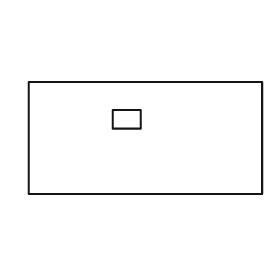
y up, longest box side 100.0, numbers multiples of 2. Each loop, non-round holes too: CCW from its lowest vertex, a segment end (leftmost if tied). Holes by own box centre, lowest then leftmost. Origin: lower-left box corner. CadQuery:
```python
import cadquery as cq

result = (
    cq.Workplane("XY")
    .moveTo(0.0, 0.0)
    .lineTo(100.0, 0.0)
    .lineTo(100.0, 48.0)
    .lineTo(0.0, 48.0)
    .close()
    .moveTo(36.0, 28.0)
    .lineTo(48.0, 28.0)
    .lineTo(48.0, 36.0)
    .lineTo(36.0, 36.0)
    .close()
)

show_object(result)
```